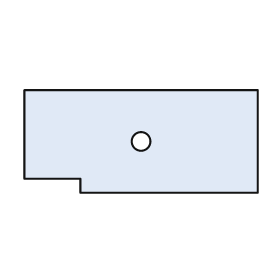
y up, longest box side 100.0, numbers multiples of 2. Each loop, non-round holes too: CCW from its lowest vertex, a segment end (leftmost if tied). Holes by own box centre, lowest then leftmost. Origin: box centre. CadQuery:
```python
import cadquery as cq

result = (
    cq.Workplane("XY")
    .moveTo(-26.0, -22.0)
    .lineTo(50.0, -22.0)
    .lineTo(50.0, 22.0)
    .lineTo(-50.0, 22.0)
    .lineTo(-50.0, -16.0)
    .lineTo(-26.0, -16.0)
    .close()
    .moveTo(0.0, 0.0)
    .circle(4.0)
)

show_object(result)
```